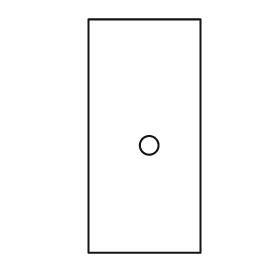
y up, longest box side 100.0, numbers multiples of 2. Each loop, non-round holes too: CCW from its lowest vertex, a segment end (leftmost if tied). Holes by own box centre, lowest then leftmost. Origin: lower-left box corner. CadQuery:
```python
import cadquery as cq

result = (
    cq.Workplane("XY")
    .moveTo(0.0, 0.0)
    .lineTo(48.0, 0.0)
    .lineTo(48.0, 100.0)
    .lineTo(0.0, 100.0)
    .close()
    .moveTo(26.0, 46.0)
    .circle(4.0)
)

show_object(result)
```